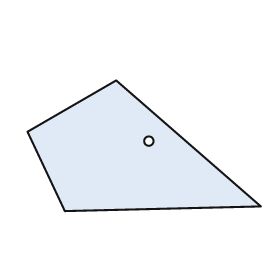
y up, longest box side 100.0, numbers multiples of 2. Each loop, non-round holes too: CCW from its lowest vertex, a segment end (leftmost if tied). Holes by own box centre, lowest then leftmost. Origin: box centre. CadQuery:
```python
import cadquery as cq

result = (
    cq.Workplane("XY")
    .moveTo(-34.0, -28.0)
    .lineTo(50.0, -26.0)
    .lineTo(-12.0, 28.0)
    .lineTo(-50.0, 6.0)
    .close()
    .moveTo(2.0, 2.0)
    .circle(2.0)
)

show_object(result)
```